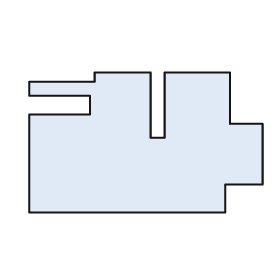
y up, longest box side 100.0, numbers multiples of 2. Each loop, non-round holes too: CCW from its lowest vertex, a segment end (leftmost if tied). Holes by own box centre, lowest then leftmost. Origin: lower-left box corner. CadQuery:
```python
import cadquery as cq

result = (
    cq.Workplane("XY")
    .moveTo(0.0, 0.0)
    .lineTo(84.0, 0.0)
    .lineTo(84.0, 12.0)
    .lineTo(100.0, 12.0)
    .lineTo(100.0, 38.0)
    .lineTo(86.0, 38.0)
    .lineTo(86.0, 60.0)
    .lineTo(58.0, 60.0)
    .lineTo(58.0, 32.0)
    .lineTo(52.0, 32.0)
    .lineTo(52.0, 60.0)
    .lineTo(28.0, 60.0)
    .lineTo(28.0, 56.0)
    .lineTo(0.0, 56.0)
    .lineTo(0.0, 50.0)
    .lineTo(26.0, 50.0)
    .lineTo(26.0, 42.0)
    .lineTo(0.0, 42.0)
    .close()
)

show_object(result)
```